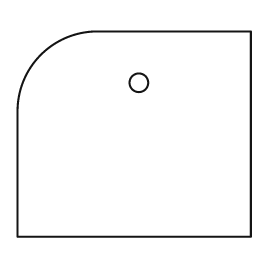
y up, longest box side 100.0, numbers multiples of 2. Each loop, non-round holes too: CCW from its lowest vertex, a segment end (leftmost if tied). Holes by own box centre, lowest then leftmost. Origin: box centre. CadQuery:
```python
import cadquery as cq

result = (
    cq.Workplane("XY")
    .moveTo(-50.0, -44.0)
    .lineTo(50.0, -44.0)
    .lineTo(50.0, 44.0)
    .lineTo(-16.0, 44.0)
    .threePointArc((-40.0, 34.0), (-50.0, 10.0))
    .close()
    .moveTo(2.0, 22.0)
    .circle(4.0)
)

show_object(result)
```